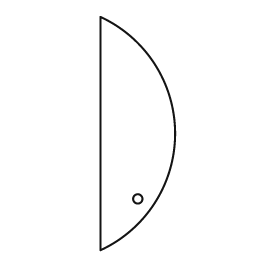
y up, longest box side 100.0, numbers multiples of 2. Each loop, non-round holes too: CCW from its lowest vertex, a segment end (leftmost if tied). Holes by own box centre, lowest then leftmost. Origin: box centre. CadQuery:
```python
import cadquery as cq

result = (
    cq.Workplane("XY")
    .moveTo(-16.0, -50.0)
    .threePointArc((16.0, 0.0), (-16.0, 50.0))
    .close()
    .moveTo(0.0, -28.0)
    .circle(2.0)
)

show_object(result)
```